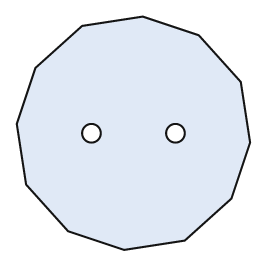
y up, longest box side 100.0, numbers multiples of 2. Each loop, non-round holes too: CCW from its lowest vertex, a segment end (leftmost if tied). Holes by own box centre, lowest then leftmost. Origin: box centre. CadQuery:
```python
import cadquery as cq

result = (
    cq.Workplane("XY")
    .moveTo(-4.0, -50.0)
    .lineTo(22.0, -46.0)
    .lineTo(42.0, -28.0)
    .lineTo(50.0, -4.0)
    .lineTo(46.0, 22.0)
    .lineTo(28.0, 42.0)
    .lineTo(4.0, 50.0)
    .lineTo(-22.0, 46.0)
    .lineTo(-42.0, 28.0)
    .lineTo(-50.0, 4.0)
    .lineTo(-46.0, -22.0)
    .lineTo(-28.0, -42.0)
    .close()
    .moveTo(-18.0, 0.0)
    .circle(4.0)
    .moveTo(18.0, 0.0)
    .circle(4.0)
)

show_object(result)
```